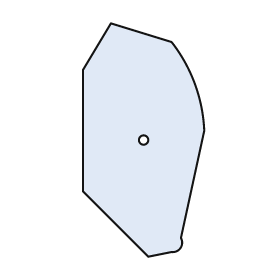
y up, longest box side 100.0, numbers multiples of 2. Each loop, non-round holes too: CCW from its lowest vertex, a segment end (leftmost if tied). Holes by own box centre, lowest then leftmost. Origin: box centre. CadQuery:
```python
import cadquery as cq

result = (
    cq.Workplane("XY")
    .moveTo(2.0, -50.0)
    .lineTo(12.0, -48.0)
    .threePointArc((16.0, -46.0), (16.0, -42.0))
    .lineTo(26.0, 4.0)
    .threePointArc((22.0, 24.0), (12.0, 42.0))
    .lineTo(-14.0, 50.0)
    .lineTo(-26.0, 30.0)
    .lineTo(-26.0, -22.0)
    .close()
    .moveTo(0.0, 0.0)
    .circle(2.0)
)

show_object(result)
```